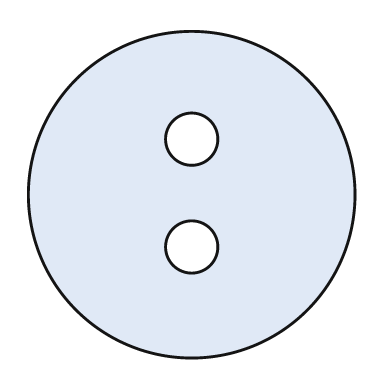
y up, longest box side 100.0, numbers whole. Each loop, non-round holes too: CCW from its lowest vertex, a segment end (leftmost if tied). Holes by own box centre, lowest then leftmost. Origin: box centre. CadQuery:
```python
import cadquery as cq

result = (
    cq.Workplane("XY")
    .moveTo(0.0, 0.0)
    .circle(50.0)
    .moveTo(0.0, -16.0)
    .circle(8.0)
    .moveTo(0.0, 17.0)
    .circle(8.0)
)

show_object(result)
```